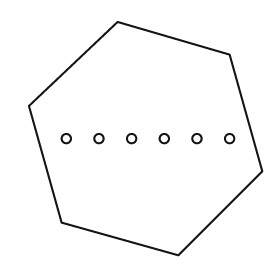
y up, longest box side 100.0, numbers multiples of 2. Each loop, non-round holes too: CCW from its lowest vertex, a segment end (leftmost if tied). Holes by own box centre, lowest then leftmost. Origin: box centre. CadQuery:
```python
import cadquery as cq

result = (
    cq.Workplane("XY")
    .moveTo(14.0, -50.0)
    .lineTo(50.0, -14.0)
    .lineTo(36.0, 36.0)
    .lineTo(-12.0, 50.0)
    .lineTo(-50.0, 14.0)
    .lineTo(-36.0, -36.0)
    .close()
    .moveTo(-34.0, 0.0)
    .circle(2.0)
    .moveTo(-20.0, 0.0)
    .circle(2.0)
    .moveTo(-6.0, 0.0)
    .circle(2.0)
    .moveTo(8.0, 0.0)
    .circle(2.0)
    .moveTo(22.0, 0.0)
    .circle(2.0)
    .moveTo(36.0, 0.0)
    .circle(2.0)
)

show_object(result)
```